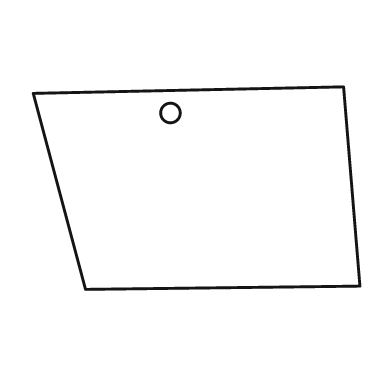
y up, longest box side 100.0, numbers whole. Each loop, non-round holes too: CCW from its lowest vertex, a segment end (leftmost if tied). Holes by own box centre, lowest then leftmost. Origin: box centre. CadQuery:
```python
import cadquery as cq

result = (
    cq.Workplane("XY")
    .moveTo(-34.0, -31.0)
    .lineTo(50.0, -30.0)
    .lineTo(45.0, 31.0)
    .lineTo(-50.0, 29.0)
    .close()
    .moveTo(-8.0, 23.0)
    .circle(3.0)
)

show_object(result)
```